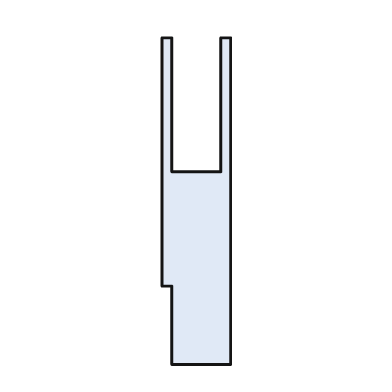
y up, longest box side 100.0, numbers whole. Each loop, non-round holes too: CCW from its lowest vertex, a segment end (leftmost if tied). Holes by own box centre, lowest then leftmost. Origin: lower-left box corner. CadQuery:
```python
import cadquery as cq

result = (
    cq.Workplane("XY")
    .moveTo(3.0, 0.0)
    .lineTo(21.0, 0.0)
    .lineTo(21.0, 100.0)
    .lineTo(18.0, 100.0)
    .lineTo(18.0, 59.0)
    .lineTo(3.0, 59.0)
    .lineTo(3.0, 100.0)
    .lineTo(0.0, 100.0)
    .lineTo(0.0, 24.0)
    .lineTo(3.0, 24.0)
    .close()
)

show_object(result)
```